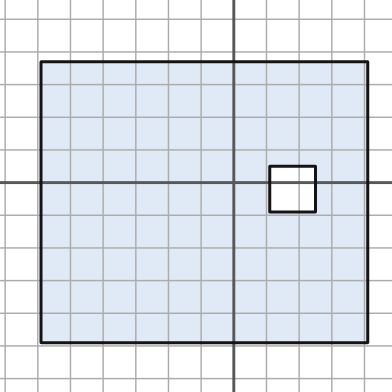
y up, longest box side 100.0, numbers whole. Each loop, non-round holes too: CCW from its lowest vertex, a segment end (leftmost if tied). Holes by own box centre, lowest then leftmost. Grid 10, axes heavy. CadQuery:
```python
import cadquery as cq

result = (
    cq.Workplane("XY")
    .moveTo(-59.0, -49.0)
    .lineTo(41.0, -49.0)
    .lineTo(41.0, 37.0)
    .lineTo(-59.0, 37.0)
    .close()
    .moveTo(11.0, -9.0)
    .lineTo(25.0, -9.0)
    .lineTo(25.0, 5.0)
    .lineTo(11.0, 5.0)
    .close()
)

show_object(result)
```